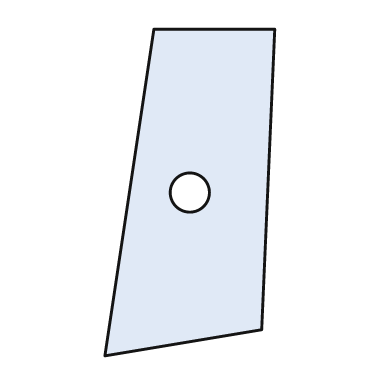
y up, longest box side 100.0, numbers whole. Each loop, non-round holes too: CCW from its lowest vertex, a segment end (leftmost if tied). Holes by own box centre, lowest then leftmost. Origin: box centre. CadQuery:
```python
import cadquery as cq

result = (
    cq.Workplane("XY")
    .moveTo(-26.0, -50.0)
    .lineTo(22.0, -42.0)
    .lineTo(26.0, 50.0)
    .lineTo(-11.0, 50.0)
    .close()
    .moveTo(0.0, 0.0)
    .circle(6.0)
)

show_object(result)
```